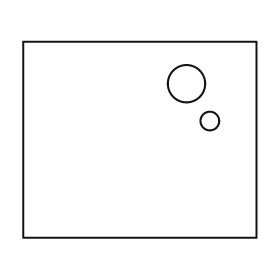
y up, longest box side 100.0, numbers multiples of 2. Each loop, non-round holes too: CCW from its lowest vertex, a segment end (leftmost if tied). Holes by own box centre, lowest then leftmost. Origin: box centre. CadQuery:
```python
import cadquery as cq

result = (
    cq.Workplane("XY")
    .moveTo(-50.0, -42.0)
    .lineTo(50.0, -42.0)
    .lineTo(50.0, 42.0)
    .lineTo(-50.0, 42.0)
    .close()
    .moveTo(30.0, 8.0)
    .circle(4.0)
    .moveTo(20.0, 24.0)
    .circle(8.0)
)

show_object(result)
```